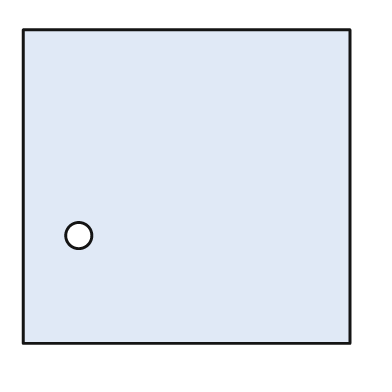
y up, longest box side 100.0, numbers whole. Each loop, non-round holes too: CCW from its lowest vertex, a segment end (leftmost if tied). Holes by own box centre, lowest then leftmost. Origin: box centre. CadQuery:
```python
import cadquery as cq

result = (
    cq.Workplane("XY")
    .moveTo(-50.0, -48.0)
    .lineTo(50.0, -48.0)
    .lineTo(50.0, 48.0)
    .lineTo(-50.0, 48.0)
    .close()
    .moveTo(-33.0, -15.0)
    .circle(4.0)
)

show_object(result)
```